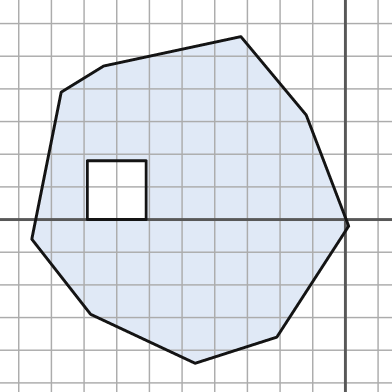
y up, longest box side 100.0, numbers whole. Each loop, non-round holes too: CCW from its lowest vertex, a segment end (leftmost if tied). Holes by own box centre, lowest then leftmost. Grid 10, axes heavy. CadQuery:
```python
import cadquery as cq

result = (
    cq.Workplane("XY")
    .moveTo(-46.0, -44.0)
    .lineTo(-21.0, -36.0)
    .lineTo(1.0, -2.0)
    .lineTo(-12.0, 32.0)
    .lineTo(-32.0, 56.0)
    .lineTo(-74.0, 47.0)
    .lineTo(-87.0, 39.0)
    .lineTo(-96.0, -6.0)
    .lineTo(-78.0, -29.0)
    .close()
    .moveTo(-79.0, 0.0)
    .lineTo(-61.0, 0.0)
    .lineTo(-61.0, 18.0)
    .lineTo(-79.0, 18.0)
    .close()
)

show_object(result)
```